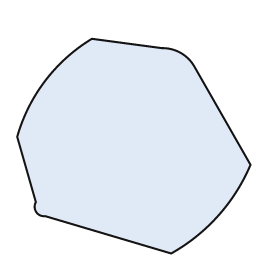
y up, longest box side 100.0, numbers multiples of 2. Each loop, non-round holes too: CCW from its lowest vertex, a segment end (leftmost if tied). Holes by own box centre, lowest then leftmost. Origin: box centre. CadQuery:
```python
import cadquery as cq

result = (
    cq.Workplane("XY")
    .moveTo(16.0, -46.0)
    .threePointArc((36.0, -30.0), (50.0, -8.0))
    .lineTo(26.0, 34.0)
    .threePointArc((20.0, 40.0), (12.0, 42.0))
    .lineTo(-18.0, 46.0)
    .threePointArc((-38.0, 28.0), (-50.0, 4.0))
    .lineTo(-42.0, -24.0)
    .threePointArc((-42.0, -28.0), (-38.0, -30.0))
    .close()
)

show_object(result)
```